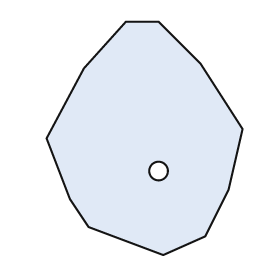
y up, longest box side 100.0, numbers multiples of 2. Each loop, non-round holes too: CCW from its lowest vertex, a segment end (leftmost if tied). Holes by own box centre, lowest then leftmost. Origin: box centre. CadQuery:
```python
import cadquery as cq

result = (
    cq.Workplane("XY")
    .moveTo(8.0, -50.0)
    .lineTo(26.0, -42.0)
    .lineTo(36.0, -22.0)
    .lineTo(42.0, 4.0)
    .lineTo(24.0, 32.0)
    .lineTo(6.0, 50.0)
    .lineTo(-8.0, 50.0)
    .lineTo(-26.0, 30.0)
    .lineTo(-42.0, 0.0)
    .lineTo(-32.0, -26.0)
    .lineTo(-24.0, -38.0)
    .close()
    .moveTo(6.0, -14.0)
    .circle(4.0)
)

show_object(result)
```